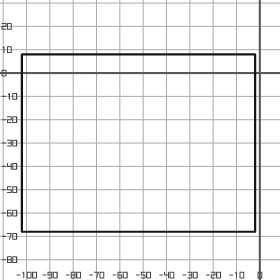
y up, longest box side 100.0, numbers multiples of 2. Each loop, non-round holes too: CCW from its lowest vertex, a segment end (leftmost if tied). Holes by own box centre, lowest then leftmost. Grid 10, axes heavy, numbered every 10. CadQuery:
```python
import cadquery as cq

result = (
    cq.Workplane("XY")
    .moveTo(-102.0, -68.0)
    .lineTo(-2.0, -68.0)
    .lineTo(-2.0, 8.0)
    .lineTo(-102.0, 8.0)
    .close()
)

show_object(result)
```